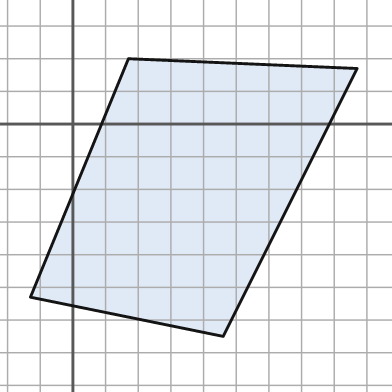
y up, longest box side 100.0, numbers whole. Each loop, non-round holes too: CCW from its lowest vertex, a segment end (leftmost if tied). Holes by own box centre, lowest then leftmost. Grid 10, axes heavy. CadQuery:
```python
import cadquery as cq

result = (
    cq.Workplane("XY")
    .moveTo(46.0, -65.0)
    .lineTo(87.0, 17.0)
    .lineTo(17.0, 20.0)
    .lineTo(-13.0, -53.0)
    .close()
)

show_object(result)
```